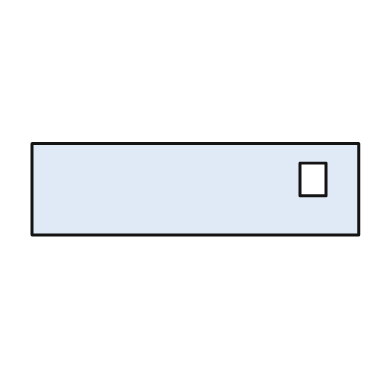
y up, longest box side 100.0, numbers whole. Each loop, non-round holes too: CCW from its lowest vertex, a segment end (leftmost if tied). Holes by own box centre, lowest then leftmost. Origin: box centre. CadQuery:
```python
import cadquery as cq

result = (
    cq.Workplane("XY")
    .moveTo(-50.0, -14.0)
    .lineTo(50.0, -14.0)
    .lineTo(50.0, 14.0)
    .lineTo(-50.0, 14.0)
    .close()
    .moveTo(32.0, -2.0)
    .lineTo(40.0, -2.0)
    .lineTo(40.0, 8.0)
    .lineTo(32.0, 8.0)
    .close()
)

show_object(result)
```